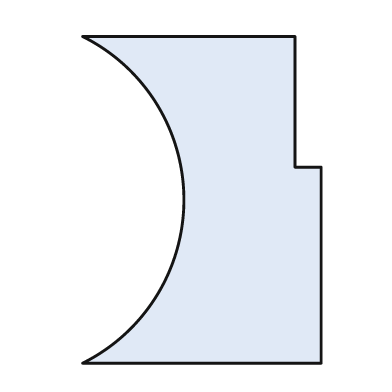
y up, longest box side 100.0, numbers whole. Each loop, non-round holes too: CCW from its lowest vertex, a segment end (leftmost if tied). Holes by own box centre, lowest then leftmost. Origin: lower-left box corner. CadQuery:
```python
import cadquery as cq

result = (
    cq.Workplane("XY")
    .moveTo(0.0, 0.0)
    .lineTo(73.0, 0.0)
    .lineTo(73.0, 60.0)
    .lineTo(65.0, 60.0)
    .lineTo(65.0, 100.0)
    .lineTo(0.0, 100.0)
    .threePointArc((31.0, 50.0), (0.0, 0.0))
    .close()
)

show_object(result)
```